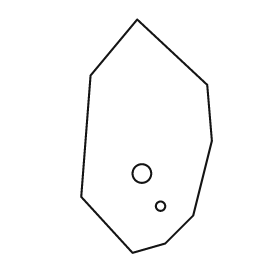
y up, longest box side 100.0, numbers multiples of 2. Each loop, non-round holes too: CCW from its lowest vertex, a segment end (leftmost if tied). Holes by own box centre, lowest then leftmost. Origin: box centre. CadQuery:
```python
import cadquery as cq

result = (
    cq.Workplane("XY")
    .moveTo(-6.0, -50.0)
    .lineTo(8.0, -46.0)
    .lineTo(20.0, -34.0)
    .lineTo(28.0, -2.0)
    .lineTo(26.0, 22.0)
    .lineTo(-4.0, 50.0)
    .lineTo(-24.0, 26.0)
    .lineTo(-28.0, -26.0)
    .close()
    .moveTo(6.0, -30.0)
    .circle(2.0)
    .moveTo(-2.0, -16.0)
    .circle(4.0)
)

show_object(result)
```